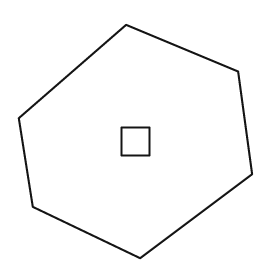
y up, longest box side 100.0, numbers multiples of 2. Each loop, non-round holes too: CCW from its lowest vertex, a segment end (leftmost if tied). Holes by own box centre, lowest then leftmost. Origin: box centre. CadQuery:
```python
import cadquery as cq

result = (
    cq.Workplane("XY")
    .moveTo(2.0, -50.0)
    .lineTo(50.0, -14.0)
    .lineTo(44.0, 30.0)
    .lineTo(-4.0, 50.0)
    .lineTo(-50.0, 10.0)
    .lineTo(-44.0, -28.0)
    .close()
    .moveTo(-6.0, -6.0)
    .lineTo(6.0, -6.0)
    .lineTo(6.0, 6.0)
    .lineTo(-6.0, 6.0)
    .close()
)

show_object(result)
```